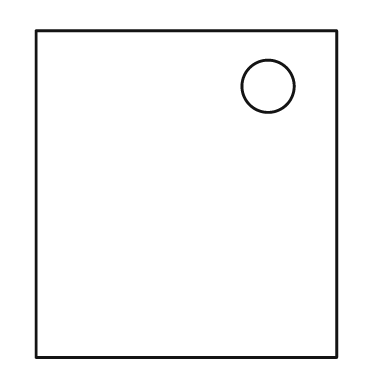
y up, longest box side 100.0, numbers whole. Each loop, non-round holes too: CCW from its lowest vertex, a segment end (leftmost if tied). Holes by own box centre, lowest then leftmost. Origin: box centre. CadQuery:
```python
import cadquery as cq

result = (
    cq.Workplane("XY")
    .moveTo(-46.0, -50.0)
    .lineTo(46.0, -50.0)
    .lineTo(46.0, 50.0)
    .lineTo(-46.0, 50.0)
    .close()
    .moveTo(25.0, 33.0)
    .circle(8.0)
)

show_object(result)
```